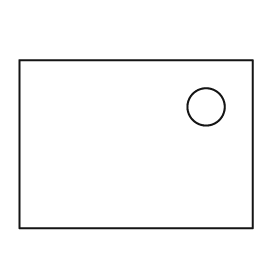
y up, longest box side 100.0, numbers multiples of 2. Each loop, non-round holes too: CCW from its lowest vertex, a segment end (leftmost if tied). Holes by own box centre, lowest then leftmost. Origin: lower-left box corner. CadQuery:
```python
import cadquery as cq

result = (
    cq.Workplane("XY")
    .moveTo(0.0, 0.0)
    .lineTo(100.0, 0.0)
    .lineTo(100.0, 72.0)
    .lineTo(0.0, 72.0)
    .close()
    .moveTo(80.0, 52.0)
    .circle(8.0)
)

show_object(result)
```